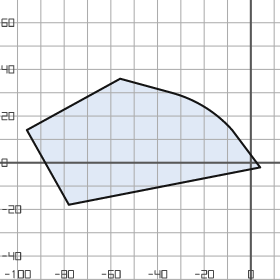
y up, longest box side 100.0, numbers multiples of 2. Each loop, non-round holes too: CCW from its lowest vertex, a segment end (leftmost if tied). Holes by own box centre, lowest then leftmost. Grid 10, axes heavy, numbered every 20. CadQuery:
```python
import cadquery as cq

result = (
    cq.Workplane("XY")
    .moveTo(-78.0, -18.0)
    .lineTo(4.0, -2.0)
    .lineTo(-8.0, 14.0)
    .threePointArc((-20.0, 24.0), (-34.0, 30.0))
    .lineTo(-56.0, 36.0)
    .lineTo(-96.0, 14.0)
    .close()
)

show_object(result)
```